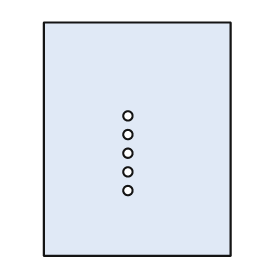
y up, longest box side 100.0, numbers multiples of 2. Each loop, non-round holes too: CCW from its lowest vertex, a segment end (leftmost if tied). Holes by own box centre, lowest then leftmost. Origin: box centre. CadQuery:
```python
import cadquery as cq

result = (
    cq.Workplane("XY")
    .moveTo(-40.0, -50.0)
    .lineTo(40.0, -50.0)
    .lineTo(40.0, 50.0)
    .lineTo(-40.0, 50.0)
    .close()
    .moveTo(-4.0, -22.0)
    .circle(2.0)
    .moveTo(-4.0, -14.0)
    .circle(2.0)
    .moveTo(-4.0, -6.0)
    .circle(2.0)
    .moveTo(-4.0, 2.0)
    .circle(2.0)
    .moveTo(-4.0, 10.0)
    .circle(2.0)
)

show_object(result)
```